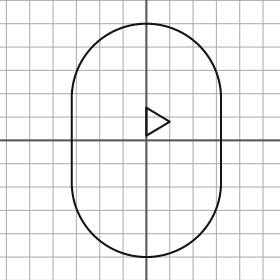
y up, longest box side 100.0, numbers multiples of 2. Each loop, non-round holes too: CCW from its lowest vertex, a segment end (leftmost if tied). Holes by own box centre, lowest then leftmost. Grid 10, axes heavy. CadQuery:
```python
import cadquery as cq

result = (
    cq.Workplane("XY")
    .moveTo(-32.0, -18.0)
    .threePointArc((0.0, -50.0), (32.0, -18.0))
    .lineTo(32.0, 18.0)
    .threePointArc((0.0, 50.0), (-32.0, 18.0))
    .close()
    .moveTo(0.0, 2.0)
    .lineTo(10.0, 8.0)
    .lineTo(0.0, 14.0)
    .close()
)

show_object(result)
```